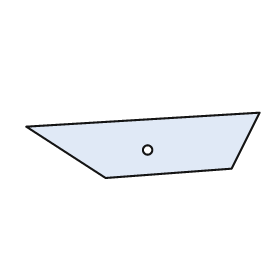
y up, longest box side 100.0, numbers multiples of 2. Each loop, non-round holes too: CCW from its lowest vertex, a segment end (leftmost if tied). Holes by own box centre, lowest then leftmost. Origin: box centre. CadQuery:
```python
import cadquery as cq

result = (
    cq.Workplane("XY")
    .moveTo(-16.0, -14.0)
    .lineTo(38.0, -10.0)
    .lineTo(50.0, 14.0)
    .lineTo(-50.0, 8.0)
    .close()
    .moveTo(2.0, -2.0)
    .circle(2.0)
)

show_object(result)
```